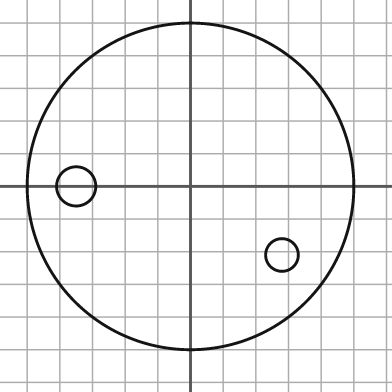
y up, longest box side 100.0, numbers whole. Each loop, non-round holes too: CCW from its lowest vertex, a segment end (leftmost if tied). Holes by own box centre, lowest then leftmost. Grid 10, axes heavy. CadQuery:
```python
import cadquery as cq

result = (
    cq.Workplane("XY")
    .moveTo(0.0, 0.0)
    .circle(50.0)
    .moveTo(28.0, -21.0)
    .circle(5.0)
    .moveTo(-35.0, 0.0)
    .circle(6.0)
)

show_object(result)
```